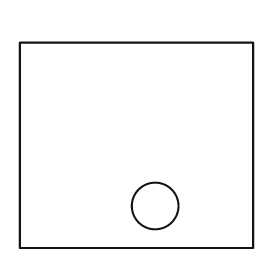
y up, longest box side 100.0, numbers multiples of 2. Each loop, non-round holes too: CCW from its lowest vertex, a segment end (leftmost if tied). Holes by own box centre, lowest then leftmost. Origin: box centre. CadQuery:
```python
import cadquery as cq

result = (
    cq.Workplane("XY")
    .moveTo(-50.0, -44.0)
    .lineTo(50.0, -44.0)
    .lineTo(50.0, 44.0)
    .lineTo(-50.0, 44.0)
    .close()
    .moveTo(8.0, -26.0)
    .circle(10.0)
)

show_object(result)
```